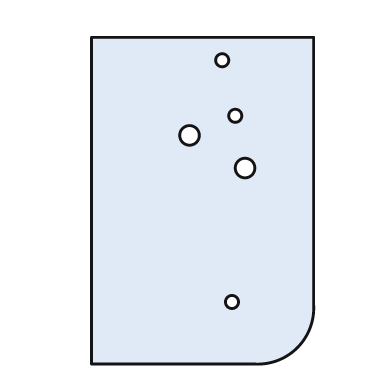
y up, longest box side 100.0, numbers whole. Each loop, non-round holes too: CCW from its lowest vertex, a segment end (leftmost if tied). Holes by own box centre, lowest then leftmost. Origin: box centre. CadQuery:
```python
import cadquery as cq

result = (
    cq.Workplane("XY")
    .moveTo(-34.0, -50.0)
    .lineTo(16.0, -50.0)
    .threePointArc((29.0, -45.0), (34.0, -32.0))
    .lineTo(34.0, 50.0)
    .lineTo(-34.0, 50.0)
    .close()
    .moveTo(9.0, -31.0)
    .circle(2.0)
    .moveTo(13.0, 10.0)
    .circle(3.0)
    .moveTo(-4.0, 20.0)
    .circle(3.0)
    .moveTo(10.0, 26.0)
    .circle(2.0)
    .moveTo(6.0, 43.0)
    .circle(2.0)
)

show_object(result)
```